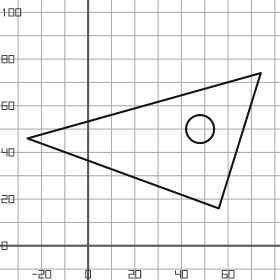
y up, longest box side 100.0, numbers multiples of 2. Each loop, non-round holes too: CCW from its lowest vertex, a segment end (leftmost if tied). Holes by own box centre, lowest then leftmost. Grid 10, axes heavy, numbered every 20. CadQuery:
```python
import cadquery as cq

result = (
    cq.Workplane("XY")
    .moveTo(56.0, 16.0)
    .lineTo(74.0, 74.0)
    .lineTo(-26.0, 46.0)
    .close()
    .moveTo(48.0, 50.0)
    .circle(6.0)
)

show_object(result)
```